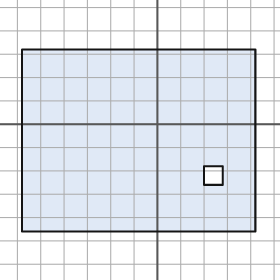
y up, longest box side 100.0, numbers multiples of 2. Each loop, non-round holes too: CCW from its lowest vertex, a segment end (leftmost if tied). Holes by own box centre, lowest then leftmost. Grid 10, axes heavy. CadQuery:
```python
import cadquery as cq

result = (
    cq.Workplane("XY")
    .moveTo(-58.0, -46.0)
    .lineTo(42.0, -46.0)
    .lineTo(42.0, 32.0)
    .lineTo(-58.0, 32.0)
    .close()
    .moveTo(20.0, -26.0)
    .lineTo(28.0, -26.0)
    .lineTo(28.0, -18.0)
    .lineTo(20.0, -18.0)
    .close()
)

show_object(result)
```